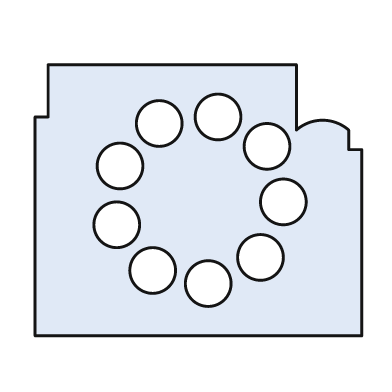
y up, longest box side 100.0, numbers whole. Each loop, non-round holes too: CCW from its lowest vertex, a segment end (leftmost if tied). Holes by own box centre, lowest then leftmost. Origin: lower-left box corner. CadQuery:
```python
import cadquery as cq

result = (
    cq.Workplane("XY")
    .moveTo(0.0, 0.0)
    .lineTo(100.0, 0.0)
    .lineTo(100.0, 57.0)
    .lineTo(96.0, 57.0)
    .lineTo(96.0, 63.0)
    .threePointArc((88.0, 66.0), (80.0, 63.0))
    .lineTo(80.0, 83.0)
    .lineTo(4.0, 83.0)
    .lineTo(4.0, 67.0)
    .lineTo(0.0, 67.0)
    .close()
    .moveTo(53.0, 16.0)
    .circle(7.0)
    .moveTo(36.0, 20.0)
    .circle(7.0)
    .moveTo(69.0, 24.0)
    .circle(7.0)
    .moveTo(25.0, 34.0)
    .circle(7.0)
    .moveTo(76.0, 41.0)
    .circle(7.0)
    .moveTo(26.0, 52.0)
    .circle(7.0)
    .moveTo(71.0, 58.0)
    .circle(7.0)
    .moveTo(38.0, 65.0)
    .circle(7.0)
    .moveTo(56.0, 67.0)
    .circle(7.0)
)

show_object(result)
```